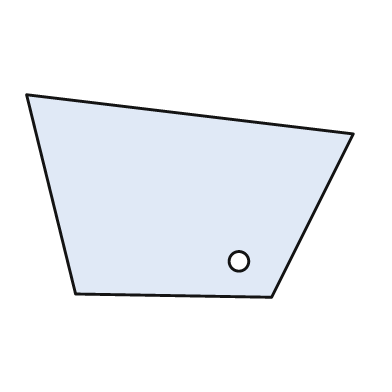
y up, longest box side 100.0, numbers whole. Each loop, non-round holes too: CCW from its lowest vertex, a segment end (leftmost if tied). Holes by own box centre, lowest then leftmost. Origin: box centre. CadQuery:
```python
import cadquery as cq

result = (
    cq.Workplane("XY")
    .moveTo(25.0, -31.0)
    .lineTo(50.0, 19.0)
    .lineTo(-50.0, 31.0)
    .lineTo(-35.0, -30.0)
    .close()
    .moveTo(15.0, -20.0)
    .circle(3.0)
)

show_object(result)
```